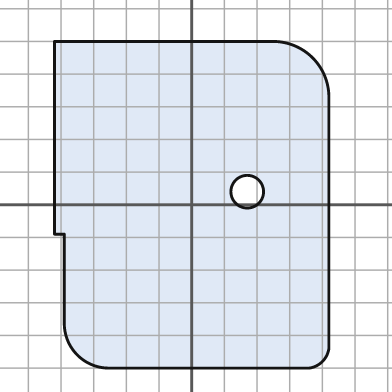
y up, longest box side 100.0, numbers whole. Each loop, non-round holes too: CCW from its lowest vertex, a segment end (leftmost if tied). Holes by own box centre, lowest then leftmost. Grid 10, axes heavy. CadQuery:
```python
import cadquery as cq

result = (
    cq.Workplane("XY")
    .moveTo(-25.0, -50.0)
    .lineTo(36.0, -50.0)
    .threePointArc((40.0, -48.0), (42.0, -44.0))
    .lineTo(42.0, 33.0)
    .threePointArc((37.0, 45.0), (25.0, 50.0))
    .lineTo(-42.0, 50.0)
    .lineTo(-42.0, -9.0)
    .lineTo(-39.0, -9.0)
    .lineTo(-39.0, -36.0)
    .threePointArc((-35.0, -46.0), (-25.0, -50.0))
    .close()
    .moveTo(17.0, 4.0)
    .circle(5.0)
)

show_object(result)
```